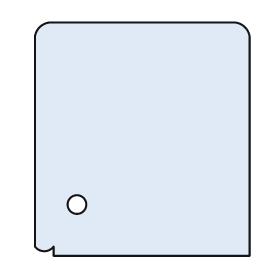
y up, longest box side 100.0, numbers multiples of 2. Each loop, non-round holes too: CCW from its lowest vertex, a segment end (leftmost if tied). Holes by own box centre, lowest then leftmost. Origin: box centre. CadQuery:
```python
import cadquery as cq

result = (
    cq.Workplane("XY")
    .moveTo(-38.0, -50.0)
    .lineTo(46.0, -50.0)
    .lineTo(46.0, 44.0)
    .threePointArc((44.0, 48.0), (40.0, 50.0))
    .lineTo(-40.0, 50.0)
    .threePointArc((-44.0, 48.0), (-46.0, 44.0))
    .lineTo(-46.0, -46.0)
    .threePointArc((-42.0, -48.0), (-38.0, -46.0))
    .close()
    .moveTo(-28.0, -28.0)
    .circle(4.0)
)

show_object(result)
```